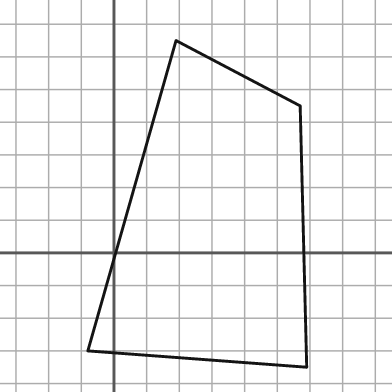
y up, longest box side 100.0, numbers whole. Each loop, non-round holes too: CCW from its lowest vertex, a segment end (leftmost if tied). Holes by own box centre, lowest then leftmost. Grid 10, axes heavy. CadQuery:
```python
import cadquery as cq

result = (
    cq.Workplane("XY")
    .moveTo(59.0, -35.0)
    .lineTo(57.0, 45.0)
    .lineTo(19.0, 65.0)
    .lineTo(-8.0, -30.0)
    .close()
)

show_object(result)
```